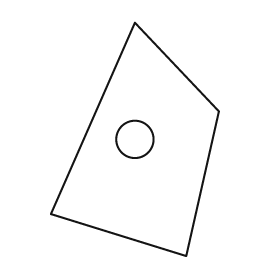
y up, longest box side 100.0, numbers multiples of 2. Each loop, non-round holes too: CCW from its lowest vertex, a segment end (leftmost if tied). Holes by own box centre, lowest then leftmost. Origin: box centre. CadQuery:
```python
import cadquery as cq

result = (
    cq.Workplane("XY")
    .moveTo(22.0, -50.0)
    .lineTo(36.0, 12.0)
    .lineTo(0.0, 50.0)
    .lineTo(-36.0, -32.0)
    .close()
    .moveTo(0.0, 0.0)
    .circle(8.0)
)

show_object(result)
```